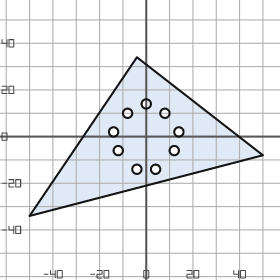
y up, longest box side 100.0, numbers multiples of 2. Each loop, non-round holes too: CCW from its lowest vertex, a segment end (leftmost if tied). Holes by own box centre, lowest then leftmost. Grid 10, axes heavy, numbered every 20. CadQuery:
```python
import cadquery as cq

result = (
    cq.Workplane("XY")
    .moveTo(-50.0, -34.0)
    .lineTo(50.0, -8.0)
    .lineTo(-4.0, 34.0)
    .close()
    .moveTo(-4.0, -14.0)
    .circle(2.0)
    .moveTo(4.0, -14.0)
    .circle(2.0)
    .moveTo(-12.0, -6.0)
    .circle(2.0)
    .moveTo(12.0, -6.0)
    .circle(2.0)
    .moveTo(-14.0, 2.0)
    .circle(2.0)
    .moveTo(14.0, 2.0)
    .circle(2.0)
    .moveTo(-8.0, 10.0)
    .circle(2.0)
    .moveTo(8.0, 10.0)
    .circle(2.0)
    .moveTo(0.0, 14.0)
    .circle(2.0)
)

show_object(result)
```